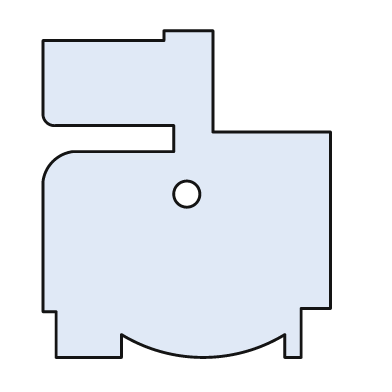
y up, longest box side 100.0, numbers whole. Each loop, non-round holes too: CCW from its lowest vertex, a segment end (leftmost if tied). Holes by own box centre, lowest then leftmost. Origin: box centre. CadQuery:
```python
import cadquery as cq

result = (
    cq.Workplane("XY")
    .moveTo(-40.0, -50.0)
    .lineTo(-20.0, -50.0)
    .lineTo(-20.0, -43.0)
    .threePointArc((5.0, -50.0), (30.0, -43.0))
    .lineTo(30.0, -50.0)
    .lineTo(35.0, -50.0)
    .lineTo(35.0, -35.0)
    .lineTo(44.0, -35.0)
    .lineTo(44.0, 19.0)
    .lineTo(8.0, 19.0)
    .lineTo(8.0, 50.0)
    .lineTo(-7.0, 50.0)
    .lineTo(-7.0, 47.0)
    .lineTo(-44.0, 47.0)
    .lineTo(-44.0, 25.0)
    .threePointArc((-43.0, 22.0), (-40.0, 21.0))
    .lineTo(-4.0, 21.0)
    .lineTo(-4.0, 13.0)
    .lineTo(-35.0, 13.0)
    .threePointArc((-41.0, 10.0), (-44.0, 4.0))
    .lineTo(-44.0, -36.0)
    .lineTo(-40.0, -36.0)
    .close()
    .moveTo(0.0, 0.0)
    .circle(4.0)
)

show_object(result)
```